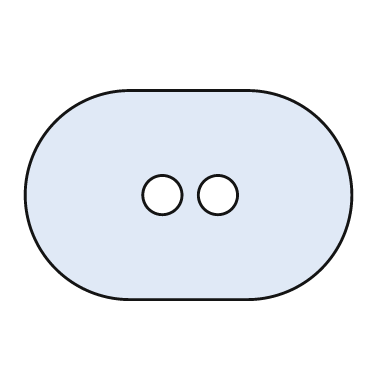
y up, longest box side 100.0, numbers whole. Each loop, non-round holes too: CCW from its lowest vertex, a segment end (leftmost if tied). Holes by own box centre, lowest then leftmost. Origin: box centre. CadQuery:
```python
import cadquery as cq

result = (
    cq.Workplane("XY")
    .moveTo(-18.0, -32.0)
    .lineTo(18.0, -32.0)
    .threePointArc((50.0, 0.0), (18.0, 32.0))
    .lineTo(-18.0, 32.0)
    .threePointArc((-50.0, 0.0), (-18.0, -32.0))
    .close()
    .moveTo(-8.0, 0.0)
    .circle(6.0)
    .moveTo(9.0, 0.0)
    .circle(6.0)
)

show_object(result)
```